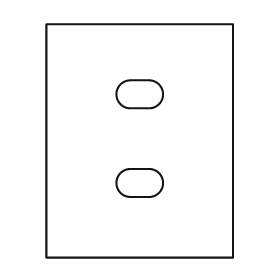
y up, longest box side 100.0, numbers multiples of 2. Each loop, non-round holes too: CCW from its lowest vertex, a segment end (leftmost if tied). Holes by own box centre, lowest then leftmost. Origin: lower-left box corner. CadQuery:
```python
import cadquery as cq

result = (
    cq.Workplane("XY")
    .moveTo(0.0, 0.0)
    .lineTo(80.0, 0.0)
    .lineTo(80.0, 100.0)
    .lineTo(0.0, 100.0)
    .close()
    .moveTo(36.0, 26.0)
    .lineTo(44.0, 26.0)
    .threePointArc((50.0, 32.0), (44.0, 38.0))
    .lineTo(36.0, 38.0)
    .threePointArc((30.0, 32.0), (36.0, 26.0))
    .close()
    .moveTo(36.0, 64.0)
    .lineTo(44.0, 64.0)
    .threePointArc((50.0, 70.0), (44.0, 76.0))
    .lineTo(36.0, 76.0)
    .threePointArc((30.0, 70.0), (36.0, 64.0))
    .close()
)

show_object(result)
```